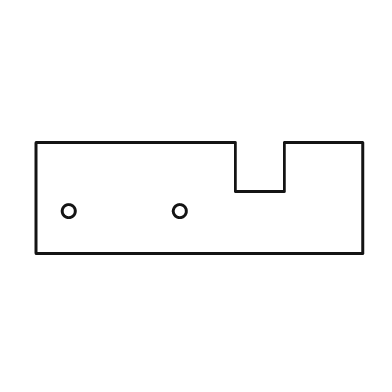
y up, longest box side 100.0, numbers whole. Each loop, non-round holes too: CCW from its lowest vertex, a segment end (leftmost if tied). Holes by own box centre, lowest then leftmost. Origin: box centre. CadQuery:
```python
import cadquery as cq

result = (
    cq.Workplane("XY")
    .moveTo(-50.0, -17.0)
    .lineTo(50.0, -17.0)
    .lineTo(50.0, 17.0)
    .lineTo(26.0, 17.0)
    .lineTo(26.0, 2.0)
    .lineTo(11.0, 2.0)
    .lineTo(11.0, 17.0)
    .lineTo(-50.0, 17.0)
    .close()
    .moveTo(-40.0, -4.0)
    .circle(2.0)
    .moveTo(-6.0, -4.0)
    .circle(2.0)
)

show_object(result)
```